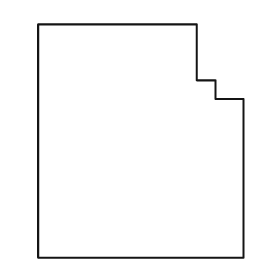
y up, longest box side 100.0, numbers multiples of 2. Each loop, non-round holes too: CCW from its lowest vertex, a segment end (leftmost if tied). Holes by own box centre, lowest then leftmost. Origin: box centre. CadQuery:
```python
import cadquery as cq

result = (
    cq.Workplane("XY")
    .moveTo(-44.0, -50.0)
    .lineTo(44.0, -50.0)
    .lineTo(44.0, 18.0)
    .lineTo(32.0, 18.0)
    .lineTo(32.0, 26.0)
    .lineTo(24.0, 26.0)
    .lineTo(24.0, 50.0)
    .lineTo(-44.0, 50.0)
    .close()
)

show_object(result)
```